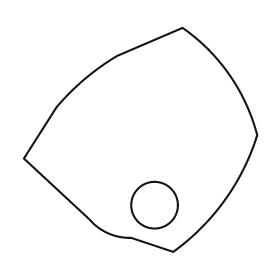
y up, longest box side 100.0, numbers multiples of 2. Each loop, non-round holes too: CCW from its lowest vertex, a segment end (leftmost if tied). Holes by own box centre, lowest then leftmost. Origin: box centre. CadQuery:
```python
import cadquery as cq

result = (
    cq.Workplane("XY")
    .moveTo(14.0, -48.0)
    .threePointArc((36.0, -26.0), (50.0, 2.0))
    .threePointArc((38.0, 28.0), (18.0, 48.0))
    .lineTo(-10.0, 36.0)
    .threePointArc((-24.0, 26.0), (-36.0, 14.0))
    .lineTo(-50.0, -8.0)
    .lineTo(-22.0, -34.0)
    .threePointArc((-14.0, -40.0), (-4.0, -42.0))
    .close()
    .moveTo(6.0, -28.0)
    .circle(10.0)
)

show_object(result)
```